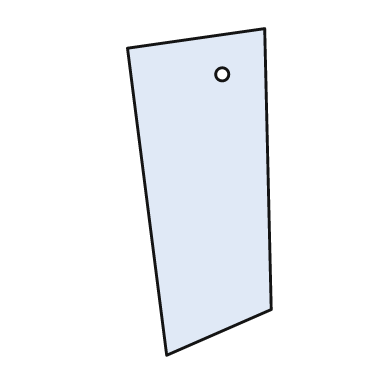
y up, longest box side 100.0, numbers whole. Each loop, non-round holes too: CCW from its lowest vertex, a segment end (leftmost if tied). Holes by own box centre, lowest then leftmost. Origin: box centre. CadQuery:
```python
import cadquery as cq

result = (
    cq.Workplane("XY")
    .moveTo(-10.0, -50.0)
    .lineTo(22.0, -36.0)
    .lineTo(20.0, 50.0)
    .lineTo(-22.0, 44.0)
    .close()
    .moveTo(7.0, 36.0)
    .circle(2.0)
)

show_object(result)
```